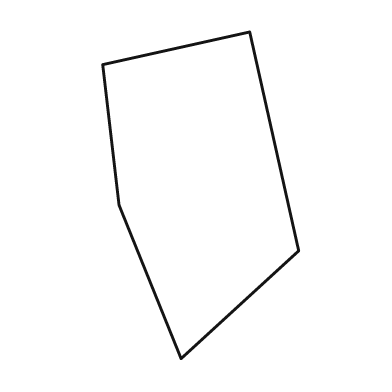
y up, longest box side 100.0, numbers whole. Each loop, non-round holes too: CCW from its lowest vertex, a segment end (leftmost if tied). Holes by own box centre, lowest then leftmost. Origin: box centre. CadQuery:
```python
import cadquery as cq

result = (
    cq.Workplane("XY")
    .moveTo(-6.0, -50.0)
    .lineTo(30.0, -17.0)
    .lineTo(15.0, 50.0)
    .lineTo(-30.0, 40.0)
    .lineTo(-25.0, -3.0)
    .close()
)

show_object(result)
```